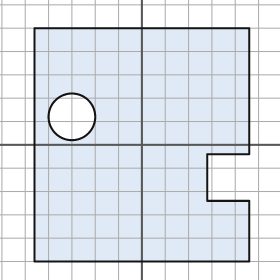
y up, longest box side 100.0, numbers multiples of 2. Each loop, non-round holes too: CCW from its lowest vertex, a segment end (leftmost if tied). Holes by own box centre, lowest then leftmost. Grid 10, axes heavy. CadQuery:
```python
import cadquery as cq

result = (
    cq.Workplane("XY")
    .moveTo(-46.0, -50.0)
    .lineTo(46.0, -50.0)
    .lineTo(46.0, -24.0)
    .lineTo(28.0, -24.0)
    .lineTo(28.0, -4.0)
    .lineTo(46.0, -4.0)
    .lineTo(46.0, 50.0)
    .lineTo(-46.0, 50.0)
    .close()
    .moveTo(-30.0, 12.0)
    .circle(10.0)
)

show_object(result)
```